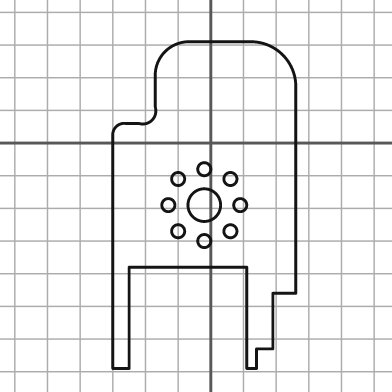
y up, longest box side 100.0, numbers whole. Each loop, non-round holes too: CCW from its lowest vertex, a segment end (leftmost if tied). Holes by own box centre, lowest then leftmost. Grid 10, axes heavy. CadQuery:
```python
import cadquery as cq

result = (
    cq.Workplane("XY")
    .moveTo(-30.0, -69.0)
    .lineTo(-25.0, -69.0)
    .lineTo(-25.0, -38.0)
    .lineTo(11.0, -38.0)
    .lineTo(11.0, -69.0)
    .lineTo(14.0, -69.0)
    .lineTo(14.0, -63.0)
    .lineTo(19.0, -63.0)
    .lineTo(19.0, -46.0)
    .lineTo(26.0, -46.0)
    .lineTo(26.0, 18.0)
    .threePointArc((22.0, 27.0), (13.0, 31.0))
    .lineTo(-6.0, 31.0)
    .threePointArc((-14.0, 28.0), (-17.0, 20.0))
    .lineTo(-17.0, 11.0)
    .threePointArc((-18.0, 7.0), (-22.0, 6.0))
    .lineTo(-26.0, 6.0)
    .threePointArc((-29.0, 5.0), (-30.0, 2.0))
    .close()
    .moveTo(-2.0, -30.0)
    .circle(2.0)
    .moveTo(-10.0, -27.0)
    .circle(2.0)
    .moveTo(6.0, -27.0)
    .circle(2.0)
    .moveTo(-13.0, -19.0)
    .circle(2.0)
    .moveTo(-2.0, -19.0)
    .circle(5.0)
    .moveTo(9.0, -19.0)
    .circle(2.0)
    .moveTo(-10.0, -11.0)
    .circle(2.0)
    .moveTo(6.0, -11.0)
    .circle(2.0)
    .moveTo(-2.0, -8.0)
    .circle(2.0)
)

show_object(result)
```